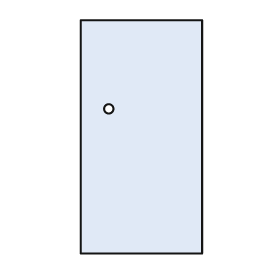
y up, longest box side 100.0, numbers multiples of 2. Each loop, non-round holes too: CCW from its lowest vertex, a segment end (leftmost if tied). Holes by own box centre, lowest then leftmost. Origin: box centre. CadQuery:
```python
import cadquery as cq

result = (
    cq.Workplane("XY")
    .moveTo(-26.0, -50.0)
    .lineTo(26.0, -50.0)
    .lineTo(26.0, 50.0)
    .lineTo(-26.0, 50.0)
    .close()
    .moveTo(-14.0, 12.0)
    .circle(2.0)
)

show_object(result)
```